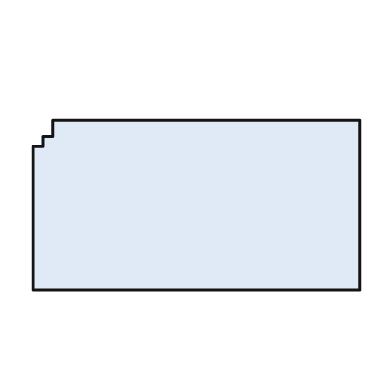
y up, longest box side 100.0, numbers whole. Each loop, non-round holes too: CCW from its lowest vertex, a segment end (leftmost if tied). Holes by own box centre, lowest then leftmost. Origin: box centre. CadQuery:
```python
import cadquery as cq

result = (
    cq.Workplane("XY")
    .moveTo(-50.0, -26.0)
    .lineTo(50.0, -26.0)
    .lineTo(50.0, 26.0)
    .lineTo(-44.0, 26.0)
    .lineTo(-44.0, 21.0)
    .lineTo(-47.0, 21.0)
    .lineTo(-47.0, 18.0)
    .lineTo(-50.0, 18.0)
    .close()
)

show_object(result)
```